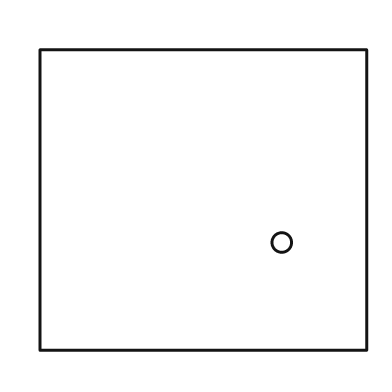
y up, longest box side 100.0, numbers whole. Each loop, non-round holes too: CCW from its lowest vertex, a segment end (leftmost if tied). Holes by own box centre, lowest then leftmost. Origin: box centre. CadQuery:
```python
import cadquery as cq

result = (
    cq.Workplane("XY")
    .moveTo(-50.0, -46.0)
    .lineTo(50.0, -46.0)
    .lineTo(50.0, 46.0)
    .lineTo(-50.0, 46.0)
    .close()
    .moveTo(24.0, -13.0)
    .circle(3.0)
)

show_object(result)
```